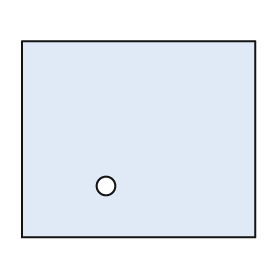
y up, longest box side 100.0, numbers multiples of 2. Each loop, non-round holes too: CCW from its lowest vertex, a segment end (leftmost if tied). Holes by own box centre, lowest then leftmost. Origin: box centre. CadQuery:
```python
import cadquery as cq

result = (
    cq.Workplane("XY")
    .moveTo(-50.0, -42.0)
    .lineTo(50.0, -42.0)
    .lineTo(50.0, 42.0)
    .lineTo(-50.0, 42.0)
    .close()
    .moveTo(-14.0, -20.0)
    .circle(4.0)
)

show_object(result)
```